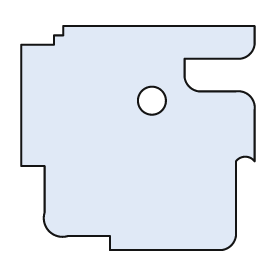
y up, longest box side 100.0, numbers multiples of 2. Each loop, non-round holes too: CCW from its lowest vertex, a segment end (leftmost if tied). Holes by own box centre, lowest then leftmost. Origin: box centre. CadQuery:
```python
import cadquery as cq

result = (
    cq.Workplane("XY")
    .moveTo(-12.0, -48.0)
    .lineTo(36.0, -48.0)
    .threePointArc((40.0, -46.0), (42.0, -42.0))
    .lineTo(42.0, -10.0)
    .threePointArc((46.0, -8.0), (50.0, -10.0))
    .lineTo(50.0, 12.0)
    .threePointArc((48.0, 18.0), (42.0, 20.0))
    .lineTo(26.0, 20.0)
    .threePointArc((22.0, 22.0), (20.0, 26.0))
    .lineTo(20.0, 34.0)
    .lineTo(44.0, 34.0)
    .threePointArc((48.0, 36.0), (50.0, 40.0))
    .lineTo(50.0, 48.0)
    .lineTo(-32.0, 48.0)
    .lineTo(-32.0, 44.0)
    .lineTo(-36.0, 44.0)
    .lineTo(-36.0, 40.0)
    .lineTo(-50.0, 40.0)
    .lineTo(-50.0, -12.0)
    .lineTo(-40.0, -12.0)
    .lineTo(-40.0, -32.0)
    .threePointArc((-38.0, -40.0), (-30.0, -42.0))
    .lineTo(-12.0, -42.0)
    .close()
    .moveTo(6.0, 16.0)
    .circle(6.0)
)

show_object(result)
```